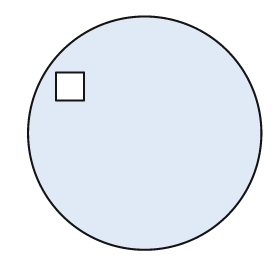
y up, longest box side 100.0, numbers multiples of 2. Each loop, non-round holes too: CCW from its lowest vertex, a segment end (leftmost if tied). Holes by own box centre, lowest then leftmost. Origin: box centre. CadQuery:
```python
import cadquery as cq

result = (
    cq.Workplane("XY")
    .moveTo(0.0, 0.0)
    .circle(50.0)
    .moveTo(-38.0, 14.0)
    .lineTo(-26.0, 14.0)
    .lineTo(-26.0, 26.0)
    .lineTo(-38.0, 26.0)
    .close()
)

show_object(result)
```